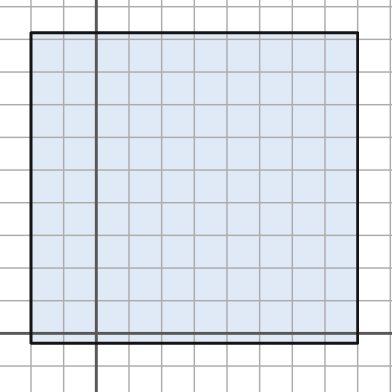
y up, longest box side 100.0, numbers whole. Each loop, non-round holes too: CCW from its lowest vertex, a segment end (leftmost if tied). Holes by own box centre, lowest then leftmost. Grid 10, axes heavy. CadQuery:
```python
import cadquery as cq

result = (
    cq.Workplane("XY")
    .moveTo(-20.0, -3.0)
    .lineTo(80.0, -3.0)
    .lineTo(80.0, 92.0)
    .lineTo(-20.0, 92.0)
    .close()
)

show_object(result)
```